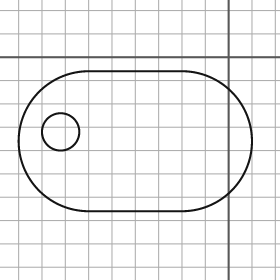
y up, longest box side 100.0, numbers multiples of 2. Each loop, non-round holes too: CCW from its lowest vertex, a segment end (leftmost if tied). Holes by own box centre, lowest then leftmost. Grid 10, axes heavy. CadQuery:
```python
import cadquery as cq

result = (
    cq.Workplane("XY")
    .moveTo(-60.0, -66.0)
    .lineTo(-20.0, -66.0)
    .threePointArc((10.0, -36.0), (-20.0, -6.0))
    .lineTo(-60.0, -6.0)
    .threePointArc((-90.0, -36.0), (-60.0, -66.0))
    .close()
    .moveTo(-72.0, -32.0)
    .circle(8.0)
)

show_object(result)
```